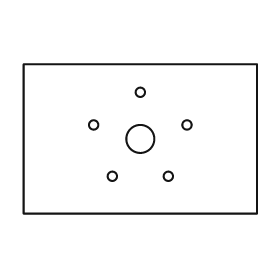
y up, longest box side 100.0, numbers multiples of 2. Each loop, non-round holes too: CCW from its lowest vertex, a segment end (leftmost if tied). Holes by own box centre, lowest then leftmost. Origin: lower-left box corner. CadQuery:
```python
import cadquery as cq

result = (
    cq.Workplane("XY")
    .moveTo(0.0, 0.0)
    .lineTo(100.0, 0.0)
    .lineTo(100.0, 64.0)
    .lineTo(0.0, 64.0)
    .close()
    .moveTo(38.0, 16.0)
    .circle(2.0)
    .moveTo(62.0, 16.0)
    .circle(2.0)
    .moveTo(50.0, 32.0)
    .circle(6.0)
    .moveTo(30.0, 38.0)
    .circle(2.0)
    .moveTo(70.0, 38.0)
    .circle(2.0)
    .moveTo(50.0, 52.0)
    .circle(2.0)
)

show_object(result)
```